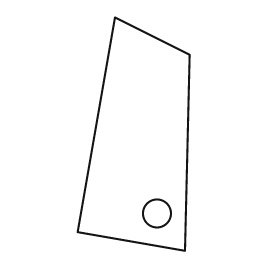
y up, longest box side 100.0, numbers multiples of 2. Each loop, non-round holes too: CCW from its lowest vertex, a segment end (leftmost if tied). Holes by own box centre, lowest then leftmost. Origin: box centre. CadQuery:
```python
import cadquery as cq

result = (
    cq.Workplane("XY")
    .moveTo(22.0, -50.0)
    .lineTo(24.0, 34.0)
    .lineTo(-8.0, 50.0)
    .lineTo(-24.0, -42.0)
    .close()
    .moveTo(10.0, -34.0)
    .circle(6.0)
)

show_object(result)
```